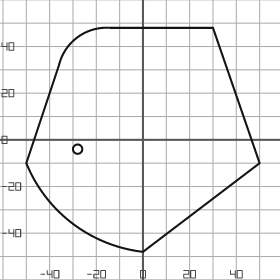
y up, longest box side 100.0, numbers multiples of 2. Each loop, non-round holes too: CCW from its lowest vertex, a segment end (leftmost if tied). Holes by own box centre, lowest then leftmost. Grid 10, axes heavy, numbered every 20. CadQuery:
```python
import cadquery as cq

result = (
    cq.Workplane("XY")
    .moveTo(0.0, -48.0)
    .lineTo(50.0, -10.0)
    .lineTo(30.0, 48.0)
    .lineTo(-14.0, 48.0)
    .threePointArc((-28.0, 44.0), (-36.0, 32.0))
    .lineTo(-50.0, -10.0)
    .threePointArc((-30.0, -36.0), (0.0, -48.0))
    .close()
    .moveTo(-28.0, -4.0)
    .circle(2.0)
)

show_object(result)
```